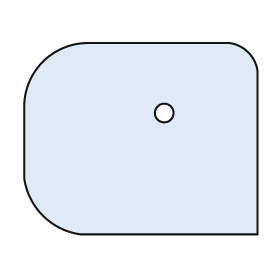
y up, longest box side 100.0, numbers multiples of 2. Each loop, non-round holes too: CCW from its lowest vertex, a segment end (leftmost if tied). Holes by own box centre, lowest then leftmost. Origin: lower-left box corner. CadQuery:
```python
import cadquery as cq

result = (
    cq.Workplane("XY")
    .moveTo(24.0, 0.0)
    .lineTo(100.0, 0.0)
    .lineTo(100.0, 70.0)
    .threePointArc((96.0, 78.0), (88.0, 82.0))
    .lineTo(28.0, 82.0)
    .threePointArc((8.0, 74.0), (0.0, 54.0))
    .lineTo(0.0, 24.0)
    .threePointArc((8.0, 8.0), (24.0, 0.0))
    .close()
    .moveTo(60.0, 52.0)
    .circle(4.0)
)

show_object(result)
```